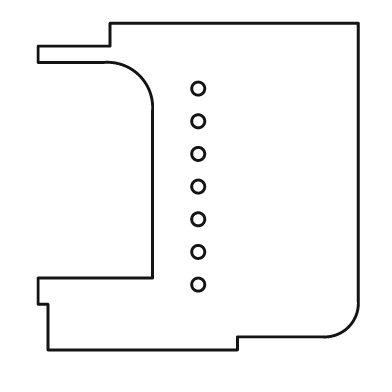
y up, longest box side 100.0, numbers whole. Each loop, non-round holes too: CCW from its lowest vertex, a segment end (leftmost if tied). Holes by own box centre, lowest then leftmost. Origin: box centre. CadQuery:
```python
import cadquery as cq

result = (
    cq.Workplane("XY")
    .moveTo(-46.0, -50.0)
    .lineTo(12.0, -50.0)
    .lineTo(12.0, -46.0)
    .lineTo(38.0, -46.0)
    .threePointArc((46.0, -43.0), (49.0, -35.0))
    .lineTo(49.0, 50.0)
    .lineTo(-27.0, 50.0)
    .lineTo(-27.0, 43.0)
    .lineTo(-49.0, 43.0)
    .lineTo(-49.0, 38.0)
    .lineTo(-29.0, 38.0)
    .threePointArc((-18.0, 34.0), (-14.0, 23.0))
    .lineTo(-14.0, -28.0)
    .lineTo(-49.0, -28.0)
    .lineTo(-49.0, -36.0)
    .lineTo(-46.0, -36.0)
    .close()
    .moveTo(0.0, -30.0)
    .circle(2.0)
    .moveTo(0.0, -20.0)
    .circle(2.0)
    .moveTo(0.0, -10.0)
    .circle(2.0)
    .moveTo(0.0, 0.0)
    .circle(2.0)
    .moveTo(0.0, 10.0)
    .circle(2.0)
    .moveTo(0.0, 20.0)
    .circle(2.0)
    .moveTo(0.0, 30.0)
    .circle(2.0)
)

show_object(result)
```